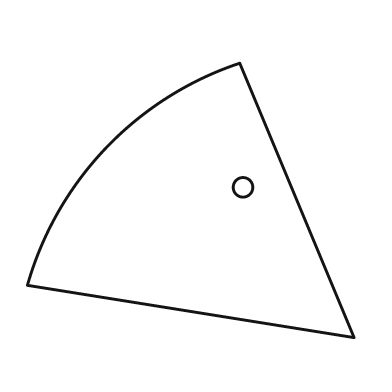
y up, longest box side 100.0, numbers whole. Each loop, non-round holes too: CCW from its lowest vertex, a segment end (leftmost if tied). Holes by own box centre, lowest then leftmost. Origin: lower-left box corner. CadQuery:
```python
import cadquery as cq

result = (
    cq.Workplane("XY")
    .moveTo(100.0, 0.0)
    .lineTo(65.0, 84.0)
    .threePointArc((24.0, 58.0), (0.0, 16.0))
    .close()
    .moveTo(66.0, 46.0)
    .circle(3.0)
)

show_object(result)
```